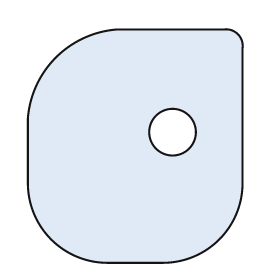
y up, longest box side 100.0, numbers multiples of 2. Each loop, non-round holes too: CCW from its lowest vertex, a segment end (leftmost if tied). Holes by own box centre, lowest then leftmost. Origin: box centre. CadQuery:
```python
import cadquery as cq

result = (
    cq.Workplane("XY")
    .moveTo(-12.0, -50.0)
    .lineTo(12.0, -50.0)
    .threePointArc((36.0, -40.0), (46.0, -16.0))
    .lineTo(46.0, 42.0)
    .threePointArc((44.0, 48.0), (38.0, 50.0))
    .lineTo(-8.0, 50.0)
    .threePointArc((-34.0, 38.0), (-46.0, 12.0))
    .lineTo(-46.0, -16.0)
    .threePointArc((-36.0, -40.0), (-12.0, -50.0))
    .close()
    .moveTo(16.0, 6.0)
    .circle(10.0)
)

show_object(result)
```